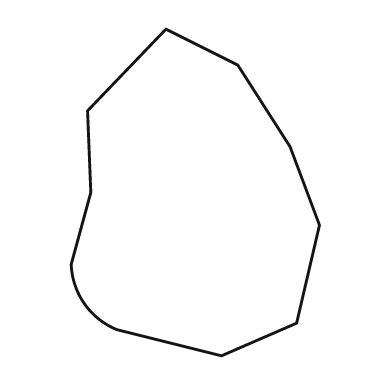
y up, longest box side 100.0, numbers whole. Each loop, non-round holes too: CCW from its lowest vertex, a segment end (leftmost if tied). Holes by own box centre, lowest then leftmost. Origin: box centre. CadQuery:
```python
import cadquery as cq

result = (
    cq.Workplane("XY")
    .moveTo(8.0, -50.0)
    .lineTo(31.0, -40.0)
    .lineTo(38.0, -10.0)
    .lineTo(29.0, 14.0)
    .lineTo(13.0, 39.0)
    .lineTo(-9.0, 50.0)
    .lineTo(-33.0, 25.0)
    .lineTo(-32.0, 0.0)
    .lineTo(-38.0, -22.0)
    .threePointArc((-34.0, -34.0), (-24.0, -42.0))
    .close()
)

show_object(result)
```